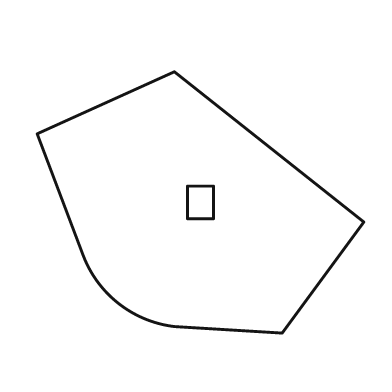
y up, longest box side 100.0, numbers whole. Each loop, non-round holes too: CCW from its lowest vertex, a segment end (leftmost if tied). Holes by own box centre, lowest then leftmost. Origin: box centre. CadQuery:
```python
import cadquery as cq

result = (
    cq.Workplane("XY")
    .moveTo(25.0, -40.0)
    .lineTo(50.0, -6.0)
    .lineTo(-8.0, 40.0)
    .lineTo(-50.0, 21.0)
    .lineTo(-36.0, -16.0)
    .threePointArc((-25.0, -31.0), (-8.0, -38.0))
    .close()
    .moveTo(-4.0, -5.0)
    .lineTo(4.0, -5.0)
    .lineTo(4.0, 5.0)
    .lineTo(-4.0, 5.0)
    .close()
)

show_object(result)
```